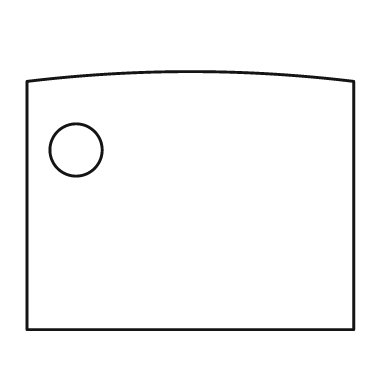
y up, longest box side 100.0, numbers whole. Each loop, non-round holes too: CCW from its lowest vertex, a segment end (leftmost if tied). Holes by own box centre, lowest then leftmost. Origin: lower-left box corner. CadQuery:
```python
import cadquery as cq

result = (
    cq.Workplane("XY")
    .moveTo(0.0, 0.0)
    .lineTo(100.0, 0.0)
    .lineTo(100.0, 76.0)
    .threePointArc((50.0, 79.0), (0.0, 76.0))
    .close()
    .moveTo(15.0, 55.0)
    .circle(8.0)
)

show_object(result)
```